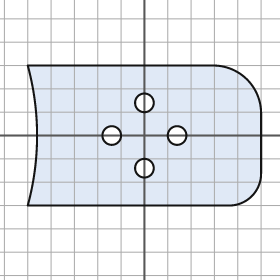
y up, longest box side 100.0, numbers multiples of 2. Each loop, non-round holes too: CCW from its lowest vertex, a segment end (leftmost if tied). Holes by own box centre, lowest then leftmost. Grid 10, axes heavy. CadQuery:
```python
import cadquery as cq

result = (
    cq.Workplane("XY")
    .moveTo(-50.0, -30.0)
    .lineTo(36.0, -30.0)
    .threePointArc((46.0, -26.0), (50.0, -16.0))
    .lineTo(50.0, 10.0)
    .threePointArc((44.0, 24.0), (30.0, 30.0))
    .lineTo(-50.0, 30.0)
    .threePointArc((-46.0, 0.0), (-50.0, -30.0))
    .close()
    .moveTo(0.0, -14.0)
    .circle(4.0)
    .moveTo(-14.0, 0.0)
    .circle(4.0)
    .moveTo(14.0, 0.0)
    .circle(4.0)
    .moveTo(0.0, 14.0)
    .circle(4.0)
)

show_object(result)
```